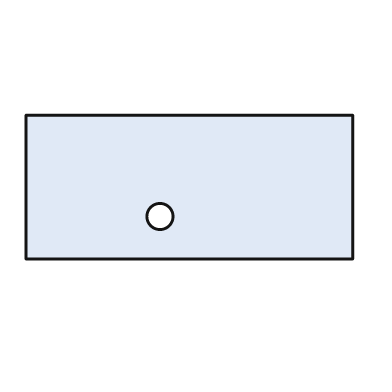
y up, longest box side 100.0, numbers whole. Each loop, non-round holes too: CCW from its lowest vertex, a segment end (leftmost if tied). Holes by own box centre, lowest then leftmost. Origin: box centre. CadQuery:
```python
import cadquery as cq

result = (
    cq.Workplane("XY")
    .moveTo(-50.0, -22.0)
    .lineTo(50.0, -22.0)
    .lineTo(50.0, 22.0)
    .lineTo(-50.0, 22.0)
    .close()
    .moveTo(-9.0, -9.0)
    .circle(4.0)
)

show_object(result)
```